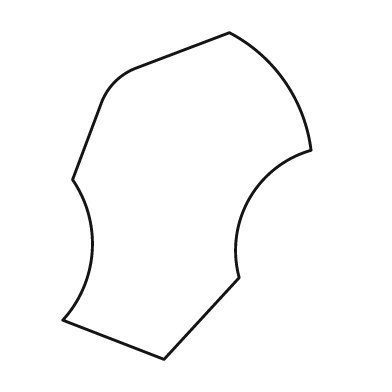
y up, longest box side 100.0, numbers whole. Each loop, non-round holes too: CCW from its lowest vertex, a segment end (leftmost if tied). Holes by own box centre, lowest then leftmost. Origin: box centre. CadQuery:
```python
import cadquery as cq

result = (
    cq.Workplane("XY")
    .moveTo(-7.0, -50.0)
    .lineTo(16.0, -25.0)
    .threePointArc((19.0, -1.0), (38.0, 14.0))
    .threePointArc((30.0, 35.0), (13.0, 50.0))
    .lineTo(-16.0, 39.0)
    .threePointArc((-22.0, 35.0), (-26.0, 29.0))
    .lineTo(-35.0, 5.0)
    .threePointArc((-29.0, -17.0), (-38.0, -38.0))
    .close()
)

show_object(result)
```